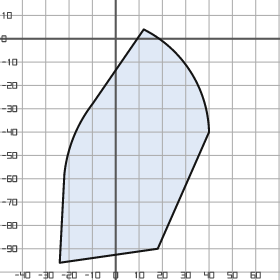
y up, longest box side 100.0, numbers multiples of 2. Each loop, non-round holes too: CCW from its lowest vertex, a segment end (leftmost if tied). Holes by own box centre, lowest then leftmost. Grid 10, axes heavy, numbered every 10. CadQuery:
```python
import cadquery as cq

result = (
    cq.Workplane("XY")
    .moveTo(-24.0, -96.0)
    .lineTo(18.0, -90.0)
    .lineTo(40.0, -40.0)
    .threePointArc((32.0, -14.0), (12.0, 4.0))
    .lineTo(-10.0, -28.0)
    .threePointArc((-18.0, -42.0), (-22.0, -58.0))
    .close()
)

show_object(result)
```